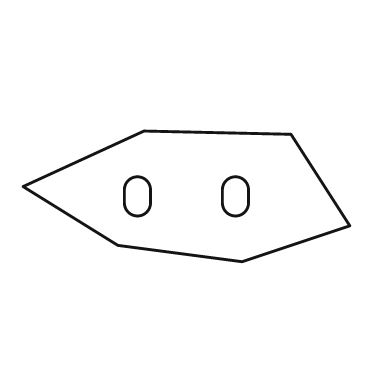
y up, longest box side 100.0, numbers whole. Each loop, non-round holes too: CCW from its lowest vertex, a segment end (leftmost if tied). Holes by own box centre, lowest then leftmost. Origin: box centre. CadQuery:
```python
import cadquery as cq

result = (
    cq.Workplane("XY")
    .moveTo(17.0, -20.0)
    .lineTo(50.0, -9.0)
    .lineTo(32.0, 19.0)
    .lineTo(-13.0, 20.0)
    .lineTo(-50.0, 3.0)
    .lineTo(-21.0, -15.0)
    .close()
    .moveTo(-19.0, -2.0)
    .threePointArc((-15.0, -6.0), (-11.0, -2.0))
    .lineTo(-11.0, 2.0)
    .threePointArc((-15.0, 6.0), (-19.0, 2.0))
    .close()
    .moveTo(11.0, -2.0)
    .threePointArc((15.0, -6.0), (19.0, -2.0))
    .lineTo(19.0, 2.0)
    .threePointArc((15.0, 6.0), (11.0, 2.0))
    .close()
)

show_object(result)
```